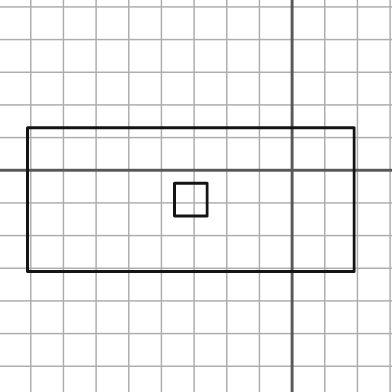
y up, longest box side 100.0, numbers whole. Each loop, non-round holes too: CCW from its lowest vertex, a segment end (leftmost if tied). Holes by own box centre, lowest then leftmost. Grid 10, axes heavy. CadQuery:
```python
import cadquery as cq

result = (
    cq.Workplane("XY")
    .moveTo(-81.0, -31.0)
    .lineTo(19.0, -31.0)
    .lineTo(19.0, 13.0)
    .lineTo(-81.0, 13.0)
    .close()
    .moveTo(-36.0, -14.0)
    .lineTo(-26.0, -14.0)
    .lineTo(-26.0, -4.0)
    .lineTo(-36.0, -4.0)
    .close()
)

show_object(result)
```